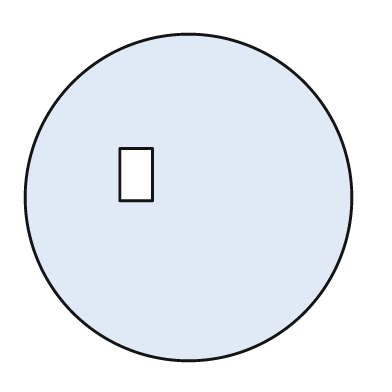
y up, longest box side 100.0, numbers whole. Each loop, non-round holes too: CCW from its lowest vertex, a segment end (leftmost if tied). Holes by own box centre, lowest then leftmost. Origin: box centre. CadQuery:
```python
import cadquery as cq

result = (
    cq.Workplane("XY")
    .moveTo(0.0, 0.0)
    .circle(50.0)
    .moveTo(-21.0, -1.0)
    .lineTo(-11.0, -1.0)
    .lineTo(-11.0, 15.0)
    .lineTo(-21.0, 15.0)
    .close()
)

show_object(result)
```